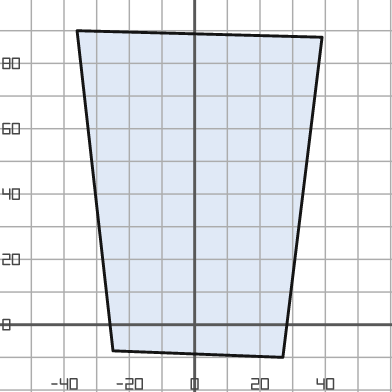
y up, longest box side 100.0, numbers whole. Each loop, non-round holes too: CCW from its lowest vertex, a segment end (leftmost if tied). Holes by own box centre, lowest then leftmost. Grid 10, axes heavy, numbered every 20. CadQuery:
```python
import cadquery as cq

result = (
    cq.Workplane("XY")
    .moveTo(27.0, -10.0)
    .lineTo(39.0, 88.0)
    .lineTo(-36.0, 90.0)
    .lineTo(-25.0, -8.0)
    .close()
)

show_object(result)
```